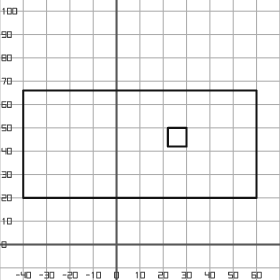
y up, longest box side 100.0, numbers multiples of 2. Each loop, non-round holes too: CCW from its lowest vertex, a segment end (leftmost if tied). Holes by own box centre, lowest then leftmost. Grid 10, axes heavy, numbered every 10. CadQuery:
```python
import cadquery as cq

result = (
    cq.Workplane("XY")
    .moveTo(-40.0, 20.0)
    .lineTo(60.0, 20.0)
    .lineTo(60.0, 66.0)
    .lineTo(-40.0, 66.0)
    .close()
    .moveTo(22.0, 42.0)
    .lineTo(30.0, 42.0)
    .lineTo(30.0, 50.0)
    .lineTo(22.0, 50.0)
    .close()
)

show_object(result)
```